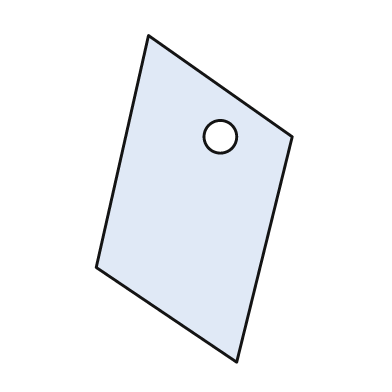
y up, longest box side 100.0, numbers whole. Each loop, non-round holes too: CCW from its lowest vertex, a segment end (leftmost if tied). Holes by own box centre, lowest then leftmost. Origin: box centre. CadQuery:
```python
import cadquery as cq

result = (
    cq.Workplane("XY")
    .moveTo(13.0, -50.0)
    .lineTo(30.0, 19.0)
    .lineTo(-14.0, 50.0)
    .lineTo(-30.0, -21.0)
    .close()
    .moveTo(8.0, 19.0)
    .circle(5.0)
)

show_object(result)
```